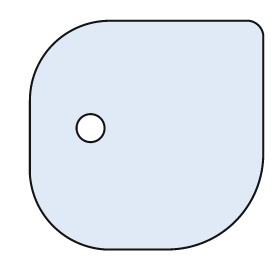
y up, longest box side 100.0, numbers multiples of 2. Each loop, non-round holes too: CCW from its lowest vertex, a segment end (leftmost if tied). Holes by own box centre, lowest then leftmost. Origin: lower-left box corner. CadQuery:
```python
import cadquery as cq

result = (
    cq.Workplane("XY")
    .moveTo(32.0, 0.0)
    .lineTo(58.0, 0.0)
    .threePointArc((88.0, 12.0), (100.0, 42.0))
    .lineTo(100.0, 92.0)
    .threePointArc((98.0, 96.0), (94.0, 98.0))
    .lineTo(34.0, 98.0)
    .threePointArc((10.0, 88.0), (0.0, 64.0))
    .lineTo(0.0, 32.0)
    .threePointArc((10.0, 10.0), (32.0, 0.0))
    .close()
    .moveTo(26.0, 52.0)
    .circle(6.0)
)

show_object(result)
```